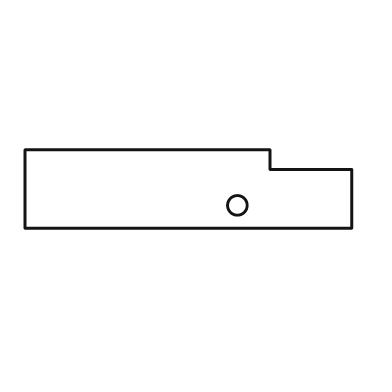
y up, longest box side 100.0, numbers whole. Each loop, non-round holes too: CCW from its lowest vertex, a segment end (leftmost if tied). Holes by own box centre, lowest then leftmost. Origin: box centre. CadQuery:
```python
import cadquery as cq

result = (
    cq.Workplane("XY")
    .moveTo(-50.0, -12.0)
    .lineTo(50.0, -12.0)
    .lineTo(50.0, 6.0)
    .lineTo(25.0, 6.0)
    .lineTo(25.0, 12.0)
    .lineTo(-50.0, 12.0)
    .close()
    .moveTo(15.0, -5.0)
    .circle(3.0)
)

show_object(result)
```